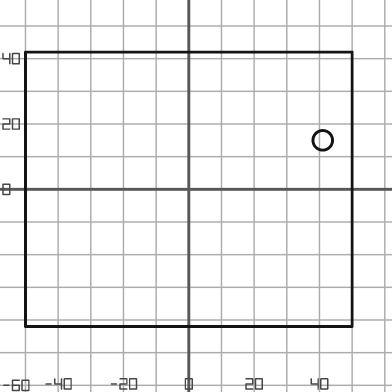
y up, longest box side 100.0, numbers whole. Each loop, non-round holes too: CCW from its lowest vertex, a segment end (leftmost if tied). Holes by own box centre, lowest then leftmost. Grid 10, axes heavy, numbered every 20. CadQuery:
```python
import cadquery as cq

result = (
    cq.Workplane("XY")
    .moveTo(-50.0, -42.0)
    .lineTo(50.0, -42.0)
    .lineTo(50.0, 42.0)
    .lineTo(-50.0, 42.0)
    .close()
    .moveTo(41.0, 15.0)
    .circle(3.0)
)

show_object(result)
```